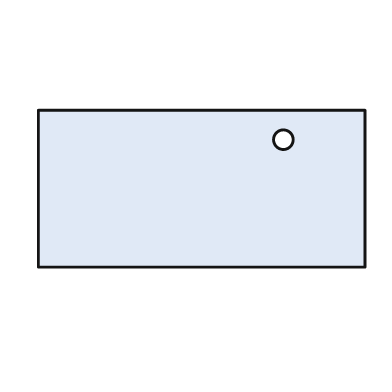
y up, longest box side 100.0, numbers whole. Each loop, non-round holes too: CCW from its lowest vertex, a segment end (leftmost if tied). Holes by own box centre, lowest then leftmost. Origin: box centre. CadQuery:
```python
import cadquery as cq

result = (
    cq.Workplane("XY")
    .moveTo(-50.0, -24.0)
    .lineTo(50.0, -24.0)
    .lineTo(50.0, 24.0)
    .lineTo(-50.0, 24.0)
    .close()
    .moveTo(25.0, 15.0)
    .circle(3.0)
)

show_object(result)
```